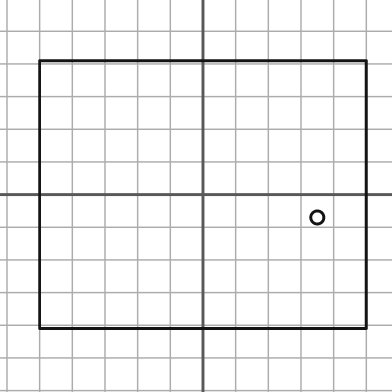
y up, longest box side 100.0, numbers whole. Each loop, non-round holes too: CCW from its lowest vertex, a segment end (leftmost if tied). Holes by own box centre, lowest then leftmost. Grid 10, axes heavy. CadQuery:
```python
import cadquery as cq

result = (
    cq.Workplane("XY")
    .moveTo(-50.0, -41.0)
    .lineTo(50.0, -41.0)
    .lineTo(50.0, 41.0)
    .lineTo(-50.0, 41.0)
    .close()
    .moveTo(35.0, -7.0)
    .circle(2.0)
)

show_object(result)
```